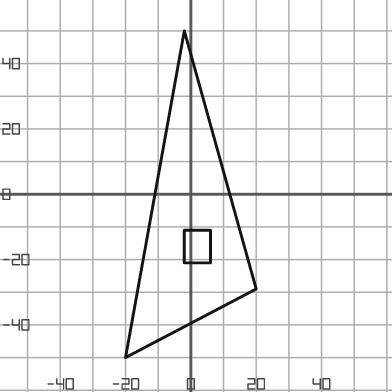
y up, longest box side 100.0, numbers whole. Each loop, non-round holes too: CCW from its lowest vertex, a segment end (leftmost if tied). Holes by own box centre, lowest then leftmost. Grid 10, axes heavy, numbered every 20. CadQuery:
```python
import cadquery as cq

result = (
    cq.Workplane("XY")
    .moveTo(-20.0, -50.0)
    .lineTo(20.0, -29.0)
    .lineTo(-2.0, 50.0)
    .close()
    .moveTo(-2.0, -21.0)
    .lineTo(6.0, -21.0)
    .lineTo(6.0, -11.0)
    .lineTo(-2.0, -11.0)
    .close()
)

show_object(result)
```